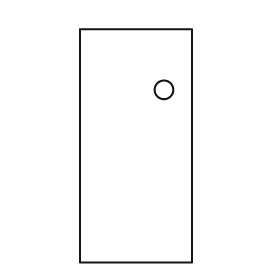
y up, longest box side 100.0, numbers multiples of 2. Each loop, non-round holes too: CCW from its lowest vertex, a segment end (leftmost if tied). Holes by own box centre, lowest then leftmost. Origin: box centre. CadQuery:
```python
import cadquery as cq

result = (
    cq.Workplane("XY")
    .moveTo(-24.0, -50.0)
    .lineTo(24.0, -50.0)
    .lineTo(24.0, 50.0)
    .lineTo(-24.0, 50.0)
    .close()
    .moveTo(12.0, 24.0)
    .circle(4.0)
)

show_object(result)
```